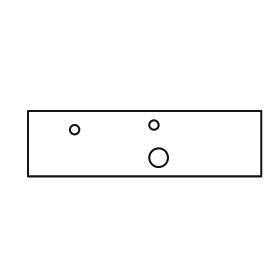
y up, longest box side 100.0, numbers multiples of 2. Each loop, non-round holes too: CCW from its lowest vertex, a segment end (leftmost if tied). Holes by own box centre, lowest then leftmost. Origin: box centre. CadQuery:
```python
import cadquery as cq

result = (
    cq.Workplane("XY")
    .moveTo(-50.0, -14.0)
    .lineTo(50.0, -14.0)
    .lineTo(50.0, 14.0)
    .lineTo(-50.0, 14.0)
    .close()
    .moveTo(6.0, -6.0)
    .circle(4.0)
    .moveTo(-30.0, 6.0)
    .circle(2.0)
    .moveTo(4.0, 8.0)
    .circle(2.0)
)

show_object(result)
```